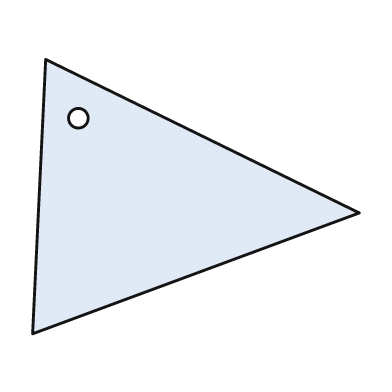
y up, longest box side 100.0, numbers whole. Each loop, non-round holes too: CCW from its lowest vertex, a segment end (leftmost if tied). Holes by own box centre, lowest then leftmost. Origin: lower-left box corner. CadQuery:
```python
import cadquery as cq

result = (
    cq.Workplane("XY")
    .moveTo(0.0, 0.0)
    .lineTo(100.0, 37.0)
    .lineTo(4.0, 84.0)
    .close()
    .moveTo(14.0, 66.0)
    .circle(3.0)
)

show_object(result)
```